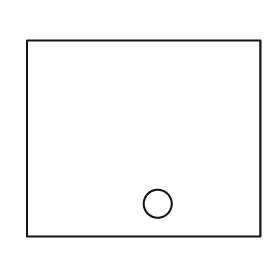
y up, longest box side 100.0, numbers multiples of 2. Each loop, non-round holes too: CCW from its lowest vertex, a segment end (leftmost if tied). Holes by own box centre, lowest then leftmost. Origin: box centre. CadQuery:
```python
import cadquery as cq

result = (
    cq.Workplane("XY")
    .moveTo(-50.0, -42.0)
    .lineTo(50.0, -42.0)
    .lineTo(50.0, 42.0)
    .lineTo(-50.0, 42.0)
    .close()
    .moveTo(6.0, -28.0)
    .circle(6.0)
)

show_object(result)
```